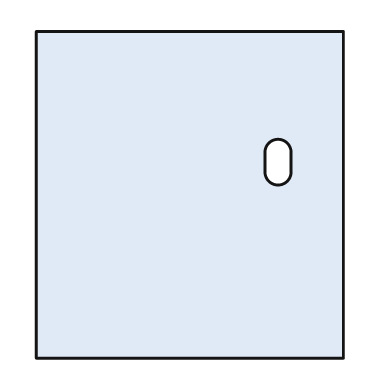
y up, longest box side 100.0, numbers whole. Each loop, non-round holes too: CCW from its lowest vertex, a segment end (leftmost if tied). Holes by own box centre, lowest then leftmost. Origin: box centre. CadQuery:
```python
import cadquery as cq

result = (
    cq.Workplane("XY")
    .moveTo(-47.0, -50.0)
    .lineTo(47.0, -50.0)
    .lineTo(47.0, 50.0)
    .lineTo(-47.0, 50.0)
    .close()
    .moveTo(23.0, 7.0)
    .threePointArc((27.0, 3.0), (31.0, 7.0))
    .lineTo(31.0, 13.0)
    .threePointArc((27.0, 17.0), (23.0, 13.0))
    .close()
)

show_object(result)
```